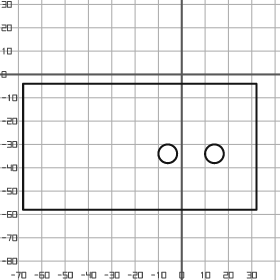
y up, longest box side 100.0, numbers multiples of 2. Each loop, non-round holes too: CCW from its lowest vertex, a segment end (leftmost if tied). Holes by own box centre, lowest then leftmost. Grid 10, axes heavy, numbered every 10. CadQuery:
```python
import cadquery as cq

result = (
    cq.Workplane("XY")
    .moveTo(-68.0, -58.0)
    .lineTo(32.0, -58.0)
    .lineTo(32.0, -4.0)
    .lineTo(-68.0, -4.0)
    .close()
    .moveTo(-6.0, -34.0)
    .circle(4.0)
    .moveTo(14.0, -34.0)
    .circle(4.0)
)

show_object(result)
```